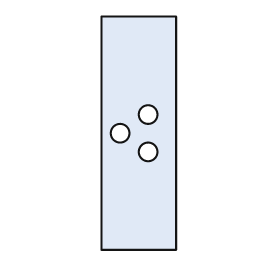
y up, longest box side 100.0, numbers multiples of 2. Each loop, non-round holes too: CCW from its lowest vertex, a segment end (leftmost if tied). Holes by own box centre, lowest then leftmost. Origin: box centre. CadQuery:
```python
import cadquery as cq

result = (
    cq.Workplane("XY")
    .moveTo(-16.0, -50.0)
    .lineTo(16.0, -50.0)
    .lineTo(16.0, 50.0)
    .lineTo(-16.0, 50.0)
    .close()
    .moveTo(4.0, -8.0)
    .circle(4.0)
    .moveTo(-8.0, 0.0)
    .circle(4.0)
    .moveTo(4.0, 8.0)
    .circle(4.0)
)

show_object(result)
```